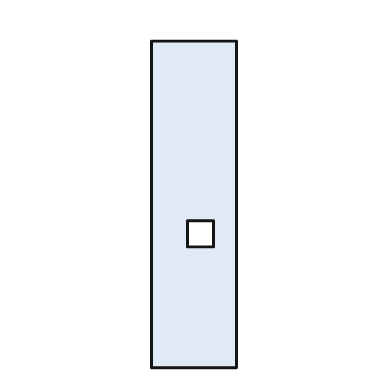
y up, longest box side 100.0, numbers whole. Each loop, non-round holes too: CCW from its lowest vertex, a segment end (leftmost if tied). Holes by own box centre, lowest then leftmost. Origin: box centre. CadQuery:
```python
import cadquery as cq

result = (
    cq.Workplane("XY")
    .moveTo(-13.0, -50.0)
    .lineTo(13.0, -50.0)
    .lineTo(13.0, 50.0)
    .lineTo(-13.0, 50.0)
    .close()
    .moveTo(-2.0, -13.0)
    .lineTo(6.0, -13.0)
    .lineTo(6.0, -5.0)
    .lineTo(-2.0, -5.0)
    .close()
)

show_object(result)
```